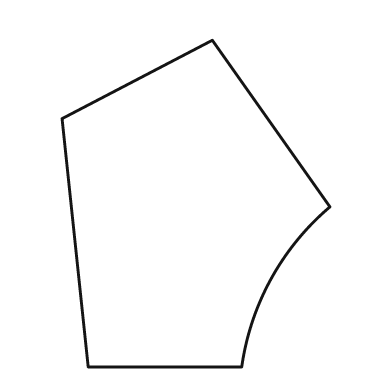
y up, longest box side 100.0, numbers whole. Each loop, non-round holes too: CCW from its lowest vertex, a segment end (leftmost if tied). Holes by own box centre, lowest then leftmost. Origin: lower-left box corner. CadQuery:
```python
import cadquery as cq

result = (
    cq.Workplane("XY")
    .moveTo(8.0, 0.0)
    .lineTo(55.0, 0.0)
    .threePointArc((64.0, 27.0), (82.0, 49.0))
    .lineTo(46.0, 100.0)
    .lineTo(0.0, 76.0)
    .close()
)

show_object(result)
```